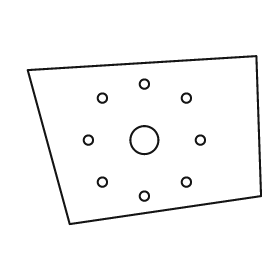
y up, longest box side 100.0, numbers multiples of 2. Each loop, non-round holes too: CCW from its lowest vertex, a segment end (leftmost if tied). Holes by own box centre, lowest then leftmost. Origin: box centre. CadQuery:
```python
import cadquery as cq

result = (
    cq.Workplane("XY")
    .moveTo(-32.0, -36.0)
    .lineTo(50.0, -24.0)
    .lineTo(48.0, 36.0)
    .lineTo(-50.0, 30.0)
    .close()
    .moveTo(0.0, -24.0)
    .circle(2.0)
    .moveTo(-18.0, -18.0)
    .circle(2.0)
    .moveTo(18.0, -18.0)
    .circle(2.0)
    .moveTo(-24.0, 0.0)
    .circle(2.0)
    .moveTo(0.0, 0.0)
    .circle(6.0)
    .moveTo(24.0, 0.0)
    .circle(2.0)
    .moveTo(-18.0, 18.0)
    .circle(2.0)
    .moveTo(18.0, 18.0)
    .circle(2.0)
    .moveTo(0.0, 24.0)
    .circle(2.0)
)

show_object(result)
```